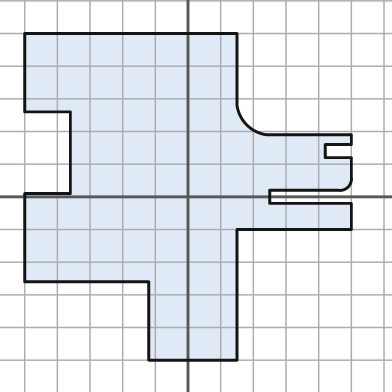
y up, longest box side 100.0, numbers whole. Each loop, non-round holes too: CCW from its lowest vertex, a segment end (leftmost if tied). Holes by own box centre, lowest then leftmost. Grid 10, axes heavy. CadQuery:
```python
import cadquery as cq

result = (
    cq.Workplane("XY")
    .moveTo(-12.0, -50.0)
    .lineTo(15.0, -50.0)
    .lineTo(15.0, -10.0)
    .lineTo(50.0, -10.0)
    .lineTo(50.0, -2.0)
    .lineTo(25.0, -2.0)
    .lineTo(25.0, 2.0)
    .lineTo(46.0, 2.0)
    .threePointArc((49.0, 3.0), (50.0, 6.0))
    .lineTo(50.0, 12.0)
    .lineTo(42.0, 12.0)
    .lineTo(42.0, 16.0)
    .lineTo(50.0, 16.0)
    .lineTo(50.0, 19.0)
    .lineTo(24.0, 19.0)
    .threePointArc((18.0, 22.0), (15.0, 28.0))
    .lineTo(15.0, 50.0)
    .lineTo(-50.0, 50.0)
    .lineTo(-50.0, 26.0)
    .lineTo(-36.0, 26.0)
    .lineTo(-36.0, 1.0)
    .lineTo(-50.0, 1.0)
    .lineTo(-50.0, -26.0)
    .lineTo(-12.0, -26.0)
    .close()
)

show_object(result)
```